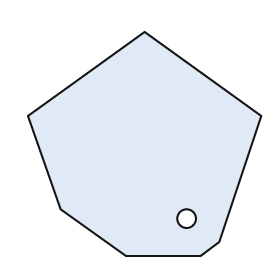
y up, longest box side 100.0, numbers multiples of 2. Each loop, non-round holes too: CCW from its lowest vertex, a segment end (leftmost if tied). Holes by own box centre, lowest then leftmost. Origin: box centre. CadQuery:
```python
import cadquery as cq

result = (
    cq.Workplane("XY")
    .moveTo(-8.0, -48.0)
    .lineTo(24.0, -48.0)
    .lineTo(32.0, -42.0)
    .lineTo(50.0, 12.0)
    .lineTo(0.0, 48.0)
    .lineTo(-50.0, 12.0)
    .lineTo(-36.0, -28.0)
    .close()
    .moveTo(18.0, -32.0)
    .circle(4.0)
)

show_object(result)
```